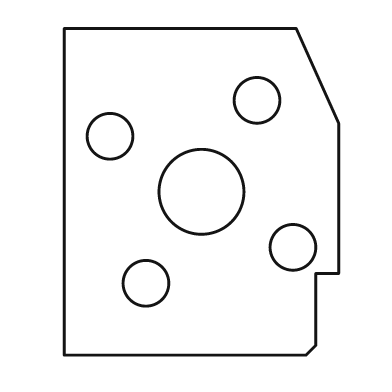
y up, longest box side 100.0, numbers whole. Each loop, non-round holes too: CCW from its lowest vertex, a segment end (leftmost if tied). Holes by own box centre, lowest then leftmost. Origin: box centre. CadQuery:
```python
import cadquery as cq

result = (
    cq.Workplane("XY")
    .moveTo(-42.0, -50.0)
    .lineTo(32.0, -50.0)
    .lineTo(35.0, -47.0)
    .lineTo(35.0, -25.0)
    .lineTo(42.0, -25.0)
    .lineTo(42.0, 21.0)
    .lineTo(29.0, 50.0)
    .lineTo(-42.0, 50.0)
    .close()
    .moveTo(-17.0, -28.0)
    .circle(7.0)
    .moveTo(28.0, -17.0)
    .circle(7.0)
    .moveTo(0.0, 0.0)
    .circle(13.0)
    .moveTo(-28.0, 17.0)
    .circle(7.0)
    .moveTo(17.0, 28.0)
    .circle(7.0)
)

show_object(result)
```